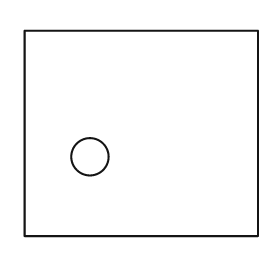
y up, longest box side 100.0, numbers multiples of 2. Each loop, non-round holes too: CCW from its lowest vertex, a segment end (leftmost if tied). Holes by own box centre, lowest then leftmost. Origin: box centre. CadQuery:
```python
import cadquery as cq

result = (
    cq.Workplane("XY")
    .moveTo(-50.0, -44.0)
    .lineTo(50.0, -44.0)
    .lineTo(50.0, 44.0)
    .lineTo(-50.0, 44.0)
    .close()
    .moveTo(-22.0, -10.0)
    .circle(8.0)
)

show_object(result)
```